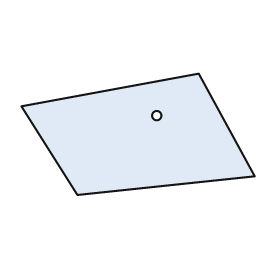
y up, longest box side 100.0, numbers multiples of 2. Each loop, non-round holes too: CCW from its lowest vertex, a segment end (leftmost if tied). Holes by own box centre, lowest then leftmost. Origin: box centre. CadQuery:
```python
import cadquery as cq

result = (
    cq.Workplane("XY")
    .moveTo(-26.0, -26.0)
    .lineTo(50.0, -18.0)
    .lineTo(26.0, 26.0)
    .lineTo(-50.0, 12.0)
    .close()
    .moveTo(8.0, 8.0)
    .circle(2.0)
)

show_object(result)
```